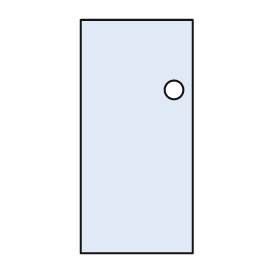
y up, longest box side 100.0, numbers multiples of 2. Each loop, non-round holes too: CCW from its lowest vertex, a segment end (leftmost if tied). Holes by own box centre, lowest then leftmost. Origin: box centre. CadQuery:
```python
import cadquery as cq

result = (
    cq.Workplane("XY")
    .moveTo(-24.0, -50.0)
    .lineTo(24.0, -50.0)
    .lineTo(24.0, 50.0)
    .lineTo(-24.0, 50.0)
    .close()
    .moveTo(16.0, 20.0)
    .circle(4.0)
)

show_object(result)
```